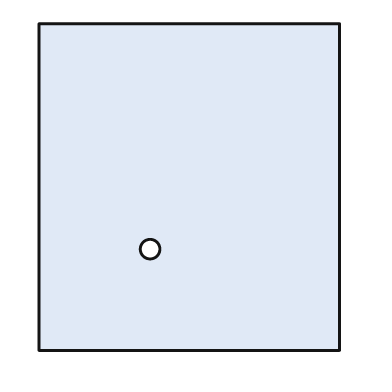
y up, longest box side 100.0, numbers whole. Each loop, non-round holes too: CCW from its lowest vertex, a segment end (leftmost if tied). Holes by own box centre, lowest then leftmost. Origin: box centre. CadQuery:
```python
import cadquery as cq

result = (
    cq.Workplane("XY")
    .moveTo(-46.0, -50.0)
    .lineTo(46.0, -50.0)
    .lineTo(46.0, 50.0)
    .lineTo(-46.0, 50.0)
    .close()
    .moveTo(-12.0, -19.0)
    .circle(3.0)
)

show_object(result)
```